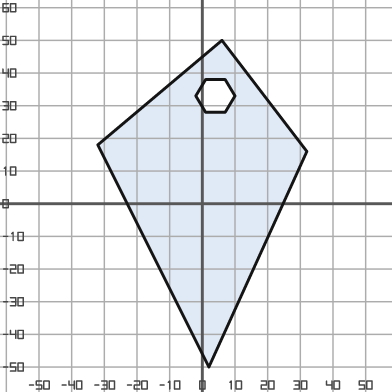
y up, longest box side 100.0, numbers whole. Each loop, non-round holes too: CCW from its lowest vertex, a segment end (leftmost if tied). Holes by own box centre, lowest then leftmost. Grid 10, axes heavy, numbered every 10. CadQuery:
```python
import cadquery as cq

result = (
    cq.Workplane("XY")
    .moveTo(2.0, -50.0)
    .lineTo(32.0, 16.0)
    .lineTo(6.0, 50.0)
    .lineTo(-32.0, 18.0)
    .close()
    .moveTo(1.0, 28.0)
    .lineTo(7.0, 28.0)
    .lineTo(10.0, 33.0)
    .lineTo(7.0, 38.0)
    .lineTo(1.0, 38.0)
    .lineTo(-2.0, 33.0)
    .close()
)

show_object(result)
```